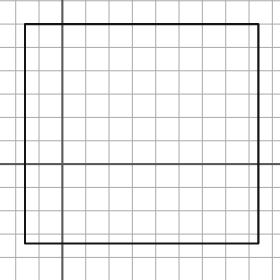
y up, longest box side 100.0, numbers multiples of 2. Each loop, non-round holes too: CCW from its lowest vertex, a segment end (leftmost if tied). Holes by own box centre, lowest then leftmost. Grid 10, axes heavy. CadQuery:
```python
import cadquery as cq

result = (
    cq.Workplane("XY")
    .moveTo(-16.0, -34.0)
    .lineTo(84.0, -34.0)
    .lineTo(84.0, 60.0)
    .lineTo(-16.0, 60.0)
    .close()
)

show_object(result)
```